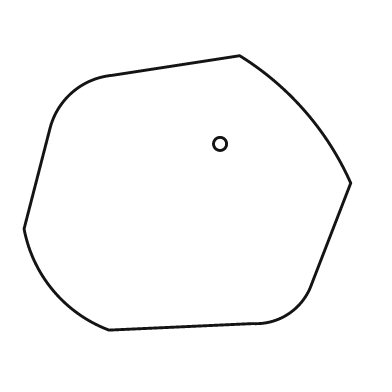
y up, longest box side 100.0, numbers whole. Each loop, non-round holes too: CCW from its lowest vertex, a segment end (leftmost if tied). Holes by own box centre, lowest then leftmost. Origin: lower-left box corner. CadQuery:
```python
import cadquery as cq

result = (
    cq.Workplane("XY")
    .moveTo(26.0, 0.0)
    .lineTo(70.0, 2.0)
    .threePointArc((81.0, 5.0), (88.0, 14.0))
    .lineTo(100.0, 45.0)
    .threePointArc((86.0, 67.0), (66.0, 84.0))
    .lineTo(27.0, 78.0)
    .threePointArc((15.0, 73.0), (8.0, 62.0))
    .lineTo(0.0, 31.0)
    .threePointArc((9.0, 12.0), (26.0, 0.0))
    .close()
    .moveTo(60.0, 57.0)
    .circle(2.0)
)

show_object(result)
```